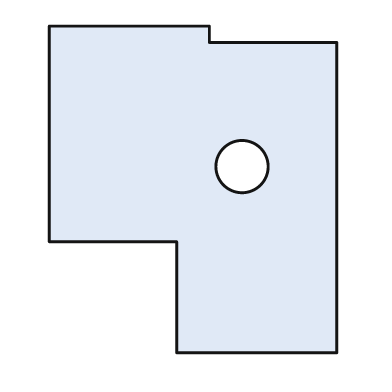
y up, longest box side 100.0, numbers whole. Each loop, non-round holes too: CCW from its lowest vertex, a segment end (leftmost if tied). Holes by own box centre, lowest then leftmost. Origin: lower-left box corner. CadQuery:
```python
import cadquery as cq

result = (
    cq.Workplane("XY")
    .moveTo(39.0, 0.0)
    .lineTo(88.0, 0.0)
    .lineTo(88.0, 95.0)
    .lineTo(49.0, 95.0)
    .lineTo(49.0, 100.0)
    .lineTo(0.0, 100.0)
    .lineTo(0.0, 34.0)
    .lineTo(39.0, 34.0)
    .close()
    .moveTo(59.0, 57.0)
    .circle(8.0)
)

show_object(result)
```